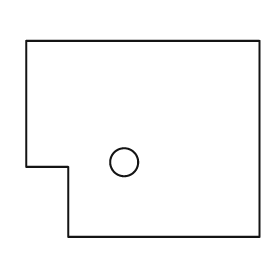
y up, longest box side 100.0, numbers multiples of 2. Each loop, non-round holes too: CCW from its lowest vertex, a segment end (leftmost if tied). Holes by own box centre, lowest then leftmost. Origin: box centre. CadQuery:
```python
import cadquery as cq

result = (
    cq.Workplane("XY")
    .moveTo(-32.0, -42.0)
    .lineTo(50.0, -42.0)
    .lineTo(50.0, 42.0)
    .lineTo(-50.0, 42.0)
    .lineTo(-50.0, -12.0)
    .lineTo(-32.0, -12.0)
    .close()
    .moveTo(-8.0, -10.0)
    .circle(6.0)
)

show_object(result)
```